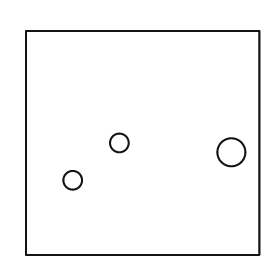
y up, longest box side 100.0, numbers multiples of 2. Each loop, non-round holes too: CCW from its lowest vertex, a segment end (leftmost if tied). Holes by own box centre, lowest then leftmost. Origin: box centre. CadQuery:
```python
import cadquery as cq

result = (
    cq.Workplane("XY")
    .moveTo(-50.0, -48.0)
    .lineTo(50.0, -48.0)
    .lineTo(50.0, 48.0)
    .lineTo(-50.0, 48.0)
    .close()
    .moveTo(-30.0, -16.0)
    .circle(4.0)
    .moveTo(38.0, -4.0)
    .circle(6.0)
    .moveTo(-10.0, 0.0)
    .circle(4.0)
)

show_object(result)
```